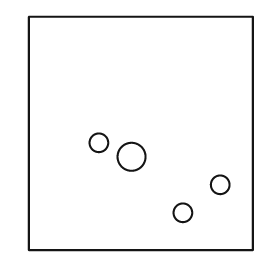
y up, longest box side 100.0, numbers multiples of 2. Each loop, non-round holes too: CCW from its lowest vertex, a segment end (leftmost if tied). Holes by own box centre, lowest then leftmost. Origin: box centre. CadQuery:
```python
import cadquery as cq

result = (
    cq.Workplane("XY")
    .moveTo(-48.0, -50.0)
    .lineTo(48.0, -50.0)
    .lineTo(48.0, 50.0)
    .lineTo(-48.0, 50.0)
    .close()
    .moveTo(18.0, -34.0)
    .circle(4.0)
    .moveTo(34.0, -22.0)
    .circle(4.0)
    .moveTo(-4.0, -10.0)
    .circle(6.0)
    .moveTo(-18.0, -4.0)
    .circle(4.0)
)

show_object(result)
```